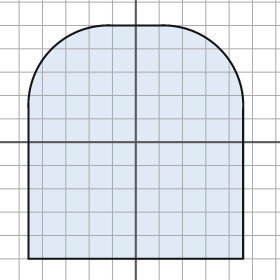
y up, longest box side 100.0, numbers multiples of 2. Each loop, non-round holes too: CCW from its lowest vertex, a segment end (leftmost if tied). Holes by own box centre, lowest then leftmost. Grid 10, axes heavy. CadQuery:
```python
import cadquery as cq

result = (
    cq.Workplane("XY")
    .moveTo(-46.0, -50.0)
    .lineTo(46.0, -50.0)
    .lineTo(46.0, 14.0)
    .threePointArc((36.0, 40.0), (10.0, 50.0))
    .lineTo(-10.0, 50.0)
    .threePointArc((-36.0, 40.0), (-46.0, 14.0))
    .close()
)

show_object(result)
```